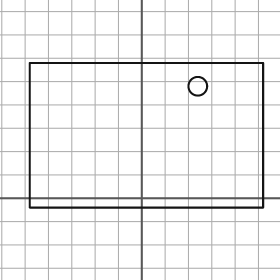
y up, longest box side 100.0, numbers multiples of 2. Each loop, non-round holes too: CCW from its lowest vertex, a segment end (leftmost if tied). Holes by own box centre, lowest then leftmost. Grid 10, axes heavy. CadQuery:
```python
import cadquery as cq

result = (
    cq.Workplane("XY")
    .moveTo(-48.0, -4.0)
    .lineTo(52.0, -4.0)
    .lineTo(52.0, 58.0)
    .lineTo(-48.0, 58.0)
    .close()
    .moveTo(24.0, 48.0)
    .circle(4.0)
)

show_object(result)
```